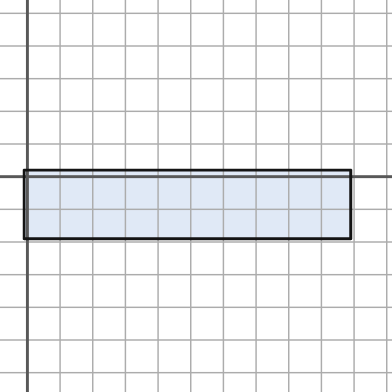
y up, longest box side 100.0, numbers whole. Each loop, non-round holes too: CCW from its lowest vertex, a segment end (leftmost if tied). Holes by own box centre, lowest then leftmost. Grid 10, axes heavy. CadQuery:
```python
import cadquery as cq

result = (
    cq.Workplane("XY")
    .moveTo(-1.0, -19.0)
    .lineTo(99.0, -19.0)
    .lineTo(99.0, 2.0)
    .lineTo(-1.0, 2.0)
    .close()
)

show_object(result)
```